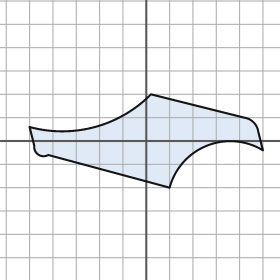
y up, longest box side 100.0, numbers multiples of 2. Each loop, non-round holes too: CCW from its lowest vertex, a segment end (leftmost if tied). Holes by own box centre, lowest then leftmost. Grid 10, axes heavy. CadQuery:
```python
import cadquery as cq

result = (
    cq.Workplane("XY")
    .moveTo(10.0, -20.0)
    .threePointArc((26.0, -2.0), (50.0, -4.0))
    .lineTo(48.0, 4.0)
    .threePointArc((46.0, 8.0), (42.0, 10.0))
    .lineTo(2.0, 20.0)
    .threePointArc((-22.0, 6.0), (-50.0, 6.0))
    .lineTo(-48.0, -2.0)
    .threePointArc((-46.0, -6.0), (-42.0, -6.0))
    .close()
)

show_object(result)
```